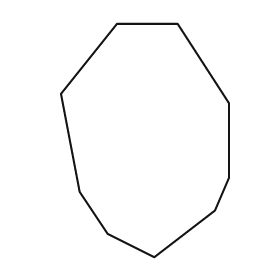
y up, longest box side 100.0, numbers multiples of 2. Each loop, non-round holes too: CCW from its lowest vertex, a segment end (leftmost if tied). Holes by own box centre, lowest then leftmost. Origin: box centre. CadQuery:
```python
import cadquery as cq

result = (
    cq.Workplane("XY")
    .moveTo(4.0, -50.0)
    .lineTo(30.0, -30.0)
    .lineTo(36.0, -16.0)
    .lineTo(36.0, 16.0)
    .lineTo(14.0, 50.0)
    .lineTo(-12.0, 50.0)
    .lineTo(-36.0, 20.0)
    .lineTo(-28.0, -22.0)
    .lineTo(-16.0, -40.0)
    .close()
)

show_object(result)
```